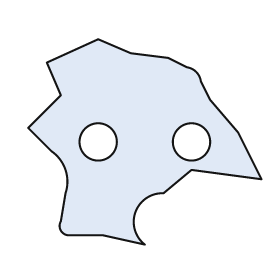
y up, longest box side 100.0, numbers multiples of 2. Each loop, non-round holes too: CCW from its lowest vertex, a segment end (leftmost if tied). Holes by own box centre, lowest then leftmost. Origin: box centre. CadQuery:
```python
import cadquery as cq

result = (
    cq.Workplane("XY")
    .moveTo(0.0, -44.0)
    .threePointArc((-4.0, -30.0), (8.0, -22.0))
    .lineTo(20.0, -12.0)
    .lineTo(50.0, -16.0)
    .lineTo(40.0, 4.0)
    .lineTo(28.0, 18.0)
    .lineTo(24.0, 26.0)
    .threePointArc((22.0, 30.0), (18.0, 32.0))
    .lineTo(10.0, 36.0)
    .lineTo(-6.0, 38.0)
    .lineTo(-20.0, 44.0)
    .lineTo(-42.0, 34.0)
    .lineTo(-36.0, 20.0)
    .lineTo(-50.0, 6.0)
    .lineTo(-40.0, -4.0)
    .threePointArc((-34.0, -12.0), (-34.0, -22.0))
    .lineTo(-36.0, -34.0)
    .threePointArc((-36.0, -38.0), (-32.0, -40.0))
    .lineTo(-18.0, -40.0)
    .close()
    .moveTo(-20.0, 0.0)
    .circle(8.0)
    .moveTo(20.0, 0.0)
    .circle(8.0)
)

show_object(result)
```